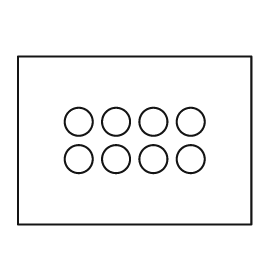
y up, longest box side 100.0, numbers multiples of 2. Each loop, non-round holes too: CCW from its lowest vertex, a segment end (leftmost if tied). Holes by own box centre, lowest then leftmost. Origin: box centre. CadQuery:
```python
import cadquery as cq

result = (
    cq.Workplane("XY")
    .moveTo(-50.0, -36.0)
    .lineTo(50.0, -36.0)
    .lineTo(50.0, 36.0)
    .lineTo(-50.0, 36.0)
    .close()
    .moveTo(-24.0, -8.0)
    .circle(6.0)
    .moveTo(-8.0, -8.0)
    .circle(6.0)
    .moveTo(8.0, -8.0)
    .circle(6.0)
    .moveTo(24.0, -8.0)
    .circle(6.0)
    .moveTo(-24.0, 8.0)
    .circle(6.0)
    .moveTo(-8.0, 8.0)
    .circle(6.0)
    .moveTo(8.0, 8.0)
    .circle(6.0)
    .moveTo(24.0, 8.0)
    .circle(6.0)
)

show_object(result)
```